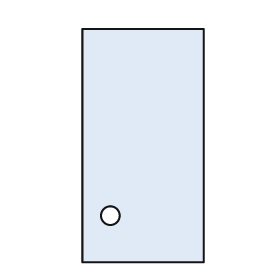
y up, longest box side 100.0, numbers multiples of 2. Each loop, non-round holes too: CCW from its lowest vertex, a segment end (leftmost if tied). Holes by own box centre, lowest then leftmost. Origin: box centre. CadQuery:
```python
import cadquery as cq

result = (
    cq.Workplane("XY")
    .moveTo(-26.0, -50.0)
    .lineTo(26.0, -50.0)
    .lineTo(26.0, 50.0)
    .lineTo(-26.0, 50.0)
    .close()
    .moveTo(-14.0, -30.0)
    .circle(4.0)
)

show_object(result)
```